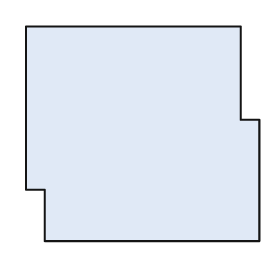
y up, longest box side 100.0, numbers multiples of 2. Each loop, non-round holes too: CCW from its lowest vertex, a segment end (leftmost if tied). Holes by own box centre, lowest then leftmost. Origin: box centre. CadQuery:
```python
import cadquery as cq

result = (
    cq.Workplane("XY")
    .moveTo(-42.0, -46.0)
    .lineTo(50.0, -46.0)
    .lineTo(50.0, 6.0)
    .lineTo(42.0, 6.0)
    .lineTo(42.0, 46.0)
    .lineTo(-50.0, 46.0)
    .lineTo(-50.0, -24.0)
    .lineTo(-42.0, -24.0)
    .close()
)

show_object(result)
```